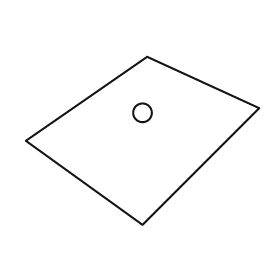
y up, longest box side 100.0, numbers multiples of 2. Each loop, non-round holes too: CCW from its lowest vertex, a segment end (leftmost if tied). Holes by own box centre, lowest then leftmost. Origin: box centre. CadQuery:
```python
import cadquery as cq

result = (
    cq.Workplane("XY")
    .moveTo(0.0, -36.0)
    .lineTo(50.0, 14.0)
    .lineTo(2.0, 36.0)
    .lineTo(-50.0, 0.0)
    .close()
    .moveTo(0.0, 12.0)
    .circle(4.0)
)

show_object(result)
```